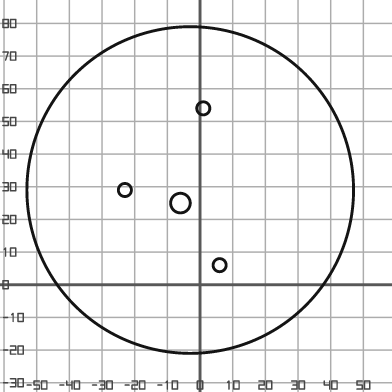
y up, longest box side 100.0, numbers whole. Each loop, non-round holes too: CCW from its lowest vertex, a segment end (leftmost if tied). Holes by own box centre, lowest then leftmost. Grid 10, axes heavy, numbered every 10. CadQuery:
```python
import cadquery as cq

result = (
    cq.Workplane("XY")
    .moveTo(-3.0, 29.0)
    .circle(50.0)
    .moveTo(6.0, 6.0)
    .circle(2.0)
    .moveTo(-6.0, 25.0)
    .circle(3.0)
    .moveTo(-23.0, 29.0)
    .circle(2.0)
    .moveTo(1.0, 54.0)
    .circle(2.0)
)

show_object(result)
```